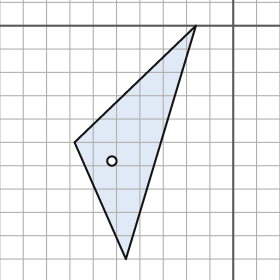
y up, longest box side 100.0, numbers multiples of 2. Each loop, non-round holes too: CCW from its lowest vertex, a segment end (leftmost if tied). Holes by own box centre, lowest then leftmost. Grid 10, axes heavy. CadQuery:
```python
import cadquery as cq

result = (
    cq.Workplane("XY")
    .moveTo(-46.0, -100.0)
    .lineTo(-16.0, 0.0)
    .lineTo(-68.0, -50.0)
    .close()
    .moveTo(-52.0, -58.0)
    .circle(2.0)
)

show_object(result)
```